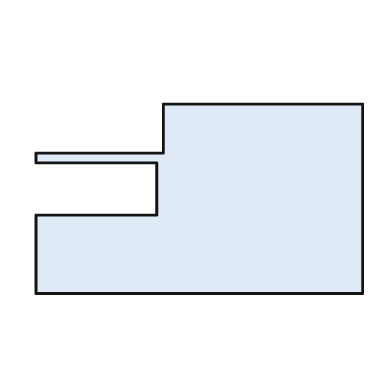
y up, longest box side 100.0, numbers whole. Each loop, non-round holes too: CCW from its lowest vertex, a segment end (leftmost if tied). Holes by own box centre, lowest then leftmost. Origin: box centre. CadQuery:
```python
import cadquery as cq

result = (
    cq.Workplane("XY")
    .moveTo(-50.0, -29.0)
    .lineTo(50.0, -29.0)
    .lineTo(50.0, 29.0)
    .lineTo(-11.0, 29.0)
    .lineTo(-11.0, 14.0)
    .lineTo(-50.0, 14.0)
    .lineTo(-50.0, 11.0)
    .lineTo(-13.0, 11.0)
    .lineTo(-13.0, -5.0)
    .lineTo(-50.0, -5.0)
    .close()
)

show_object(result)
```